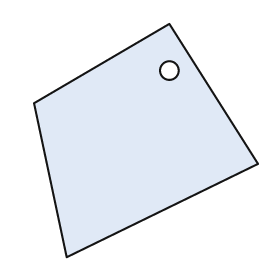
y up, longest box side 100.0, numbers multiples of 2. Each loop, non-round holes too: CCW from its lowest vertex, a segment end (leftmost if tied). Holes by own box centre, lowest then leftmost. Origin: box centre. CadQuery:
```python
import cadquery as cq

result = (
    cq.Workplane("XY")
    .moveTo(-34.0, -50.0)
    .lineTo(48.0, -10.0)
    .lineTo(10.0, 50.0)
    .lineTo(-48.0, 16.0)
    .close()
    .moveTo(10.0, 30.0)
    .circle(4.0)
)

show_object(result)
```